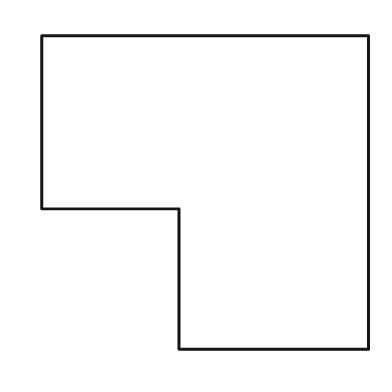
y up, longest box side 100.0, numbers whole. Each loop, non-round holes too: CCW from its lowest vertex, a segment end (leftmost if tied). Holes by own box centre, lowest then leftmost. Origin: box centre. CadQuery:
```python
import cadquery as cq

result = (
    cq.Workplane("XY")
    .moveTo(-8.0, -48.0)
    .lineTo(50.0, -48.0)
    .lineTo(50.0, 48.0)
    .lineTo(-50.0, 48.0)
    .lineTo(-50.0, -5.0)
    .lineTo(-8.0, -5.0)
    .close()
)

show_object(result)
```